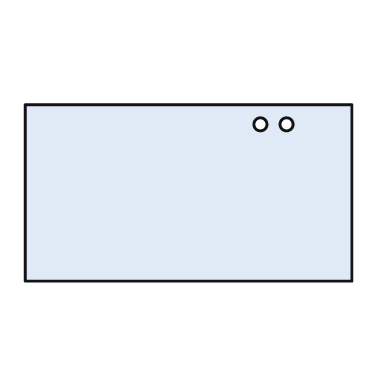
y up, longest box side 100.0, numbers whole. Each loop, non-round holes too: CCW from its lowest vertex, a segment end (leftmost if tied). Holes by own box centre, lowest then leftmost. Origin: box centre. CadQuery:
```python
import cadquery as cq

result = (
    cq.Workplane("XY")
    .moveTo(-50.0, -27.0)
    .lineTo(50.0, -27.0)
    .lineTo(50.0, 27.0)
    .lineTo(-50.0, 27.0)
    .close()
    .moveTo(22.0, 21.0)
    .circle(2.0)
    .moveTo(30.0, 21.0)
    .circle(2.0)
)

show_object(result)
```